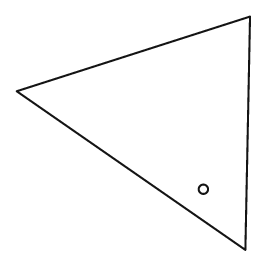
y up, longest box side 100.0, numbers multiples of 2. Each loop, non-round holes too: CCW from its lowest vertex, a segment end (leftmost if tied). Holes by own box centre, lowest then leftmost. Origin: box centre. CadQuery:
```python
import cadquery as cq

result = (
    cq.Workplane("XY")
    .moveTo(48.0, -50.0)
    .lineTo(50.0, 50.0)
    .lineTo(-50.0, 18.0)
    .close()
    .moveTo(30.0, -24.0)
    .circle(2.0)
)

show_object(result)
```